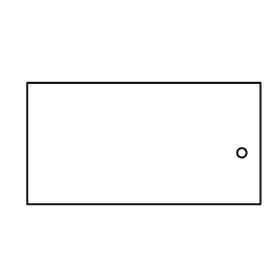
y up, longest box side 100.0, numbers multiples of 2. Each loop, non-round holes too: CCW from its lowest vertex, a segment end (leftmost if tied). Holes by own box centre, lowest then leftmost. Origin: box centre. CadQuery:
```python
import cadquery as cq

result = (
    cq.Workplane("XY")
    .moveTo(-50.0, -26.0)
    .lineTo(50.0, -26.0)
    .lineTo(50.0, 26.0)
    .lineTo(-50.0, 26.0)
    .close()
    .moveTo(42.0, -4.0)
    .circle(2.0)
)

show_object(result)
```